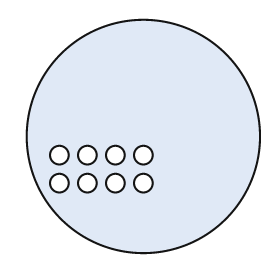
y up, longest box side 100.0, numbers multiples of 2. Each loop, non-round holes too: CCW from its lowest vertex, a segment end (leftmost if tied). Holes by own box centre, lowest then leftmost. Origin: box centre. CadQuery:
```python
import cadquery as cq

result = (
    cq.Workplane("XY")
    .moveTo(0.0, 0.0)
    .circle(50.0)
    .moveTo(-36.0, -20.0)
    .circle(4.0)
    .moveTo(-24.0, -20.0)
    .circle(4.0)
    .moveTo(-12.0, -20.0)
    .circle(4.0)
    .moveTo(0.0, -20.0)
    .circle(4.0)
    .moveTo(-36.0, -8.0)
    .circle(4.0)
    .moveTo(-24.0, -8.0)
    .circle(4.0)
    .moveTo(-12.0, -8.0)
    .circle(4.0)
    .moveTo(0.0, -8.0)
    .circle(4.0)
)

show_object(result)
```